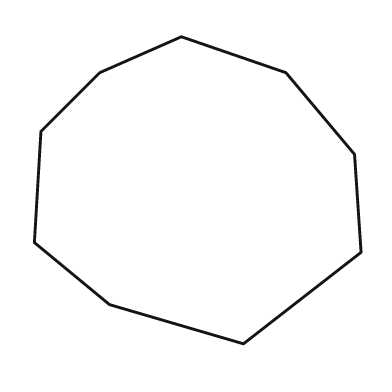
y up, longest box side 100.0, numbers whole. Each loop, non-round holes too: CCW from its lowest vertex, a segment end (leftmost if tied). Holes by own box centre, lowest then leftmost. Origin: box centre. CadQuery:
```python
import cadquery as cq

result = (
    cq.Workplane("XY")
    .moveTo(14.0, -47.0)
    .lineTo(50.0, -19.0)
    .lineTo(48.0, 11.0)
    .lineTo(27.0, 36.0)
    .lineTo(-5.0, 47.0)
    .lineTo(-30.0, 36.0)
    .lineTo(-48.0, 18.0)
    .lineTo(-50.0, -16.0)
    .lineTo(-27.0, -35.0)
    .close()
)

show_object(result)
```